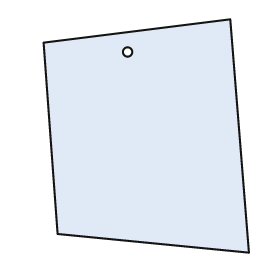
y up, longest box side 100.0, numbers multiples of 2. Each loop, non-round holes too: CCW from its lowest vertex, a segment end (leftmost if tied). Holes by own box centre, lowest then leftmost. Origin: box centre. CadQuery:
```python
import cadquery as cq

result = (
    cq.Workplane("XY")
    .moveTo(44.0, -50.0)
    .lineTo(36.0, 50.0)
    .lineTo(-44.0, 40.0)
    .lineTo(-38.0, -42.0)
    .close()
    .moveTo(-8.0, 36.0)
    .circle(2.0)
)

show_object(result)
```